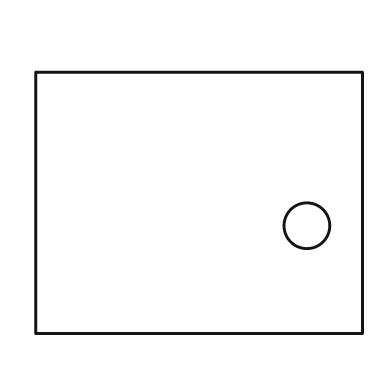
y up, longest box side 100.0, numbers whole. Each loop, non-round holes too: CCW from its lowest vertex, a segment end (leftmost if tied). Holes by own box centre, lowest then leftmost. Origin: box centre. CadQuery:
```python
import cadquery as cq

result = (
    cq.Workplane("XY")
    .moveTo(-50.0, -40.0)
    .lineTo(50.0, -40.0)
    .lineTo(50.0, 40.0)
    .lineTo(-50.0, 40.0)
    .close()
    .moveTo(33.0, -7.0)
    .circle(7.0)
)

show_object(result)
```